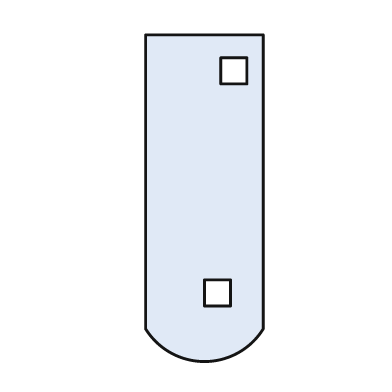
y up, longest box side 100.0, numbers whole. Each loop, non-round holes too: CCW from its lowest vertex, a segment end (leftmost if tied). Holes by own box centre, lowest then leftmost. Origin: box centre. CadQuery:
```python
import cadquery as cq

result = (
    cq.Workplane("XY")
    .moveTo(-18.0, -40.0)
    .threePointArc((0.0, -50.0), (18.0, -40.0))
    .lineTo(18.0, 50.0)
    .lineTo(-18.0, 50.0)
    .close()
    .moveTo(0.0, -33.0)
    .lineTo(8.0, -33.0)
    .lineTo(8.0, -25.0)
    .lineTo(0.0, -25.0)
    .close()
    .moveTo(5.0, 35.0)
    .lineTo(13.0, 35.0)
    .lineTo(13.0, 43.0)
    .lineTo(5.0, 43.0)
    .close()
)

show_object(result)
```